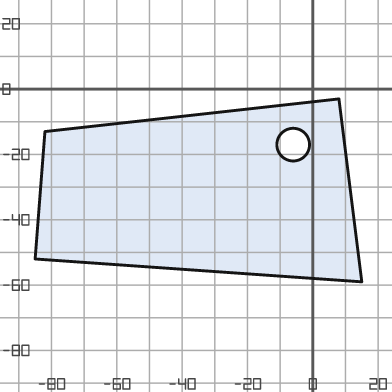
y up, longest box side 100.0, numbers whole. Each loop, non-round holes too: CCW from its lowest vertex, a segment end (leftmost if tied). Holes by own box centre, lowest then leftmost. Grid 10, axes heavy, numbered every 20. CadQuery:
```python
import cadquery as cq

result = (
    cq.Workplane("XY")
    .moveTo(15.0, -59.0)
    .lineTo(8.0, -3.0)
    .lineTo(-82.0, -13.0)
    .lineTo(-85.0, -52.0)
    .close()
    .moveTo(-6.0, -17.0)
    .circle(5.0)
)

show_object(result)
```